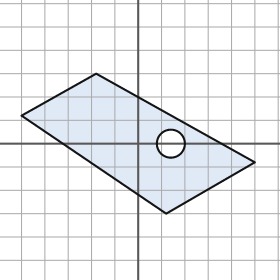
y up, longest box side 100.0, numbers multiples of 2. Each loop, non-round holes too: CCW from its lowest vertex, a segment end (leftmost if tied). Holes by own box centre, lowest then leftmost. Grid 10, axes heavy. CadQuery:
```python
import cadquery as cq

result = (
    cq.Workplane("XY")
    .moveTo(12.0, -30.0)
    .lineTo(50.0, -8.0)
    .lineTo(-18.0, 30.0)
    .lineTo(-50.0, 12.0)
    .close()
    .moveTo(14.0, 0.0)
    .circle(6.0)
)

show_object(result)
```